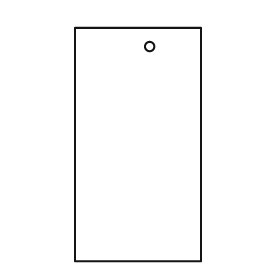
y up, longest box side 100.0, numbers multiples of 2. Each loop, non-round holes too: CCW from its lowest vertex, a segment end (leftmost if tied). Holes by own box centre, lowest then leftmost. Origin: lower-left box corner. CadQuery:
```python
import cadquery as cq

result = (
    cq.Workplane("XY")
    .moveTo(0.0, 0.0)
    .lineTo(54.0, 0.0)
    .lineTo(54.0, 100.0)
    .lineTo(0.0, 100.0)
    .close()
    .moveTo(32.0, 92.0)
    .circle(2.0)
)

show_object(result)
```